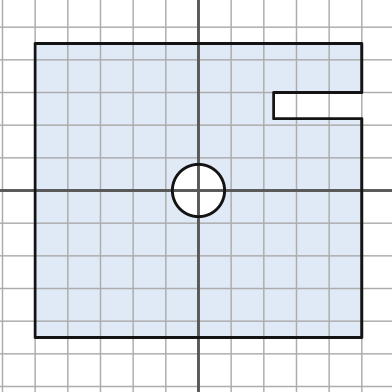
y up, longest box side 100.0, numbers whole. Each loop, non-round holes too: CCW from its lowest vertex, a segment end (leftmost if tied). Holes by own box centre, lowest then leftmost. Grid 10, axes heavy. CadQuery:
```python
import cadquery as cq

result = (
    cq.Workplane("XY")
    .moveTo(-50.0, -45.0)
    .lineTo(50.0, -45.0)
    .lineTo(50.0, 22.0)
    .lineTo(23.0, 22.0)
    .lineTo(23.0, 30.0)
    .lineTo(50.0, 30.0)
    .lineTo(50.0, 45.0)
    .lineTo(-50.0, 45.0)
    .close()
    .moveTo(0.0, 0.0)
    .circle(8.0)
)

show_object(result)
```